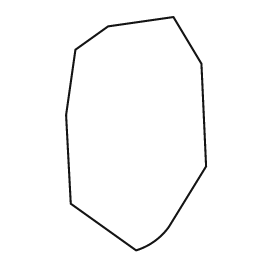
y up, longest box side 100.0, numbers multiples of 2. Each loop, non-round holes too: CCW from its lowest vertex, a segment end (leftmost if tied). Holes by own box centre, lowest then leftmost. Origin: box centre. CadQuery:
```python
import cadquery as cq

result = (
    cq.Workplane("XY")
    .moveTo(0.0, -50.0)
    .threePointArc((8.0, -46.0), (14.0, -40.0))
    .lineTo(30.0, -14.0)
    .lineTo(28.0, 30.0)
    .lineTo(16.0, 50.0)
    .lineTo(-12.0, 46.0)
    .lineTo(-26.0, 36.0)
    .lineTo(-30.0, 8.0)
    .lineTo(-28.0, -30.0)
    .close()
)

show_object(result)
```